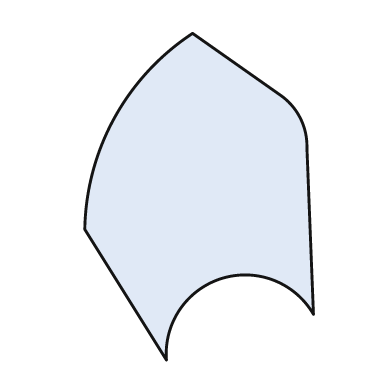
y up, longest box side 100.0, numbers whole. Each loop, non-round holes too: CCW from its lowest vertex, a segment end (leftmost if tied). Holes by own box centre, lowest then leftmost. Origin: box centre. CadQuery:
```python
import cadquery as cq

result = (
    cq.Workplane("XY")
    .moveTo(-10.0, -50.0)
    .threePointArc((7.0, -25.0), (35.0, -36.0))
    .lineTo(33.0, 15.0)
    .threePointArc((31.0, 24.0), (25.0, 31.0))
    .lineTo(-2.0, 50.0)
    .threePointArc((-26.0, 24.0), (-35.0, -10.0))
    .close()
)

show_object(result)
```